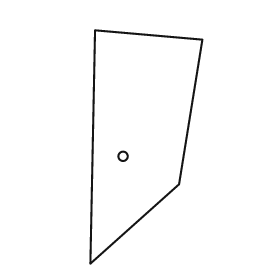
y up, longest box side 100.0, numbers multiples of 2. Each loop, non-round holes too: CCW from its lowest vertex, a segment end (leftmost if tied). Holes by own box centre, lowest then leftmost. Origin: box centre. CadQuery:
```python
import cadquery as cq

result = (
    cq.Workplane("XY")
    .moveTo(-24.0, -50.0)
    .lineTo(14.0, -16.0)
    .lineTo(24.0, 46.0)
    .lineTo(-22.0, 50.0)
    .close()
    .moveTo(-10.0, -4.0)
    .circle(2.0)
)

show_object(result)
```